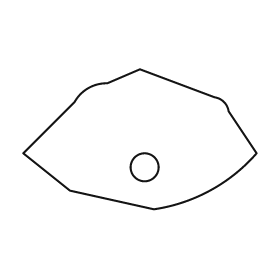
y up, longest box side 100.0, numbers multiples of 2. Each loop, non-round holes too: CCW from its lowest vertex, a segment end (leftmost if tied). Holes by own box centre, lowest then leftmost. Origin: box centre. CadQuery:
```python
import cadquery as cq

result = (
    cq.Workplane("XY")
    .moveTo(6.0, -30.0)
    .threePointArc((30.0, -22.0), (50.0, -6.0))
    .lineTo(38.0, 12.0)
    .threePointArc((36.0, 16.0), (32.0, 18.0))
    .lineTo(0.0, 30.0)
    .lineTo(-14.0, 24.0)
    .threePointArc((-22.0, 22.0), (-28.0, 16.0))
    .lineTo(-50.0, -6.0)
    .lineTo(-30.0, -22.0)
    .close()
    .moveTo(2.0, -12.0)
    .circle(6.0)
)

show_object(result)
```